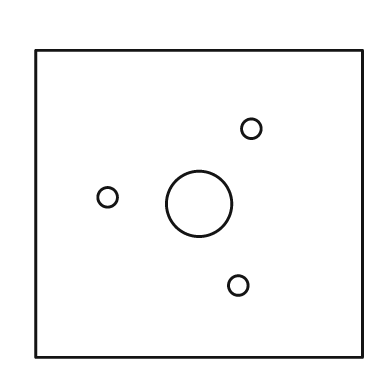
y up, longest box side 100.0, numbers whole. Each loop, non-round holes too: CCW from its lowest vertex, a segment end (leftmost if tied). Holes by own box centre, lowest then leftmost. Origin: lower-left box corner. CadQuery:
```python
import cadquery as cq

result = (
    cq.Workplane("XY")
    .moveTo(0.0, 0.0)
    .lineTo(100.0, 0.0)
    .lineTo(100.0, 94.0)
    .lineTo(0.0, 94.0)
    .close()
    .moveTo(62.0, 22.0)
    .circle(3.0)
    .moveTo(50.0, 47.0)
    .circle(10.0)
    .moveTo(22.0, 49.0)
    .circle(3.0)
    .moveTo(66.0, 70.0)
    .circle(3.0)
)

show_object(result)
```